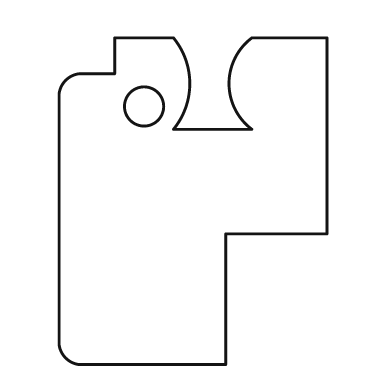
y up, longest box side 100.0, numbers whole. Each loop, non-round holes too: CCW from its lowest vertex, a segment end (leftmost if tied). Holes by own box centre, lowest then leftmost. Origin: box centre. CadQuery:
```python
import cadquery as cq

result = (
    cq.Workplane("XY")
    .moveTo(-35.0, -50.0)
    .lineTo(10.0, -50.0)
    .lineTo(10.0, -10.0)
    .lineTo(41.0, -10.0)
    .lineTo(41.0, 50.0)
    .lineTo(18.0, 50.0)
    .threePointArc((11.0, 36.0), (18.0, 22.0))
    .lineTo(-6.0, 22.0)
    .threePointArc((-1.0, 36.0), (-6.0, 50.0))
    .lineTo(-24.0, 50.0)
    .lineTo(-24.0, 39.0)
    .lineTo(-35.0, 39.0)
    .threePointArc((-39.0, 37.0), (-41.0, 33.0))
    .lineTo(-41.0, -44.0)
    .threePointArc((-39.0, -48.0), (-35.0, -50.0))
    .close()
    .moveTo(-15.0, 29.0)
    .circle(6.0)
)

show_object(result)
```